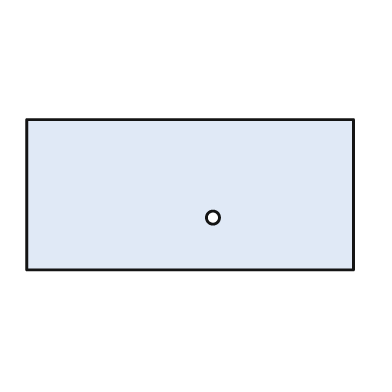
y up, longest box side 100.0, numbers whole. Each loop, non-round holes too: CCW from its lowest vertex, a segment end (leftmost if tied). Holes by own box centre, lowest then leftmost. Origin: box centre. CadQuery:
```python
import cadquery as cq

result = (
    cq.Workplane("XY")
    .moveTo(-50.0, -23.0)
    .lineTo(50.0, -23.0)
    .lineTo(50.0, 23.0)
    .lineTo(-50.0, 23.0)
    .close()
    .moveTo(7.0, -7.0)
    .circle(2.0)
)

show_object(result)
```